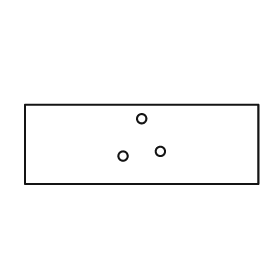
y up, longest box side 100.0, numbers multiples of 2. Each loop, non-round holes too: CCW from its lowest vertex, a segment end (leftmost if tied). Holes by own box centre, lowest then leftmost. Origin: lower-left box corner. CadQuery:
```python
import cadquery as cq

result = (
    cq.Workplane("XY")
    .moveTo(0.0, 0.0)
    .lineTo(100.0, 0.0)
    .lineTo(100.0, 34.0)
    .lineTo(0.0, 34.0)
    .close()
    .moveTo(42.0, 12.0)
    .circle(2.0)
    .moveTo(58.0, 14.0)
    .circle(2.0)
    .moveTo(50.0, 28.0)
    .circle(2.0)
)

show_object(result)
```